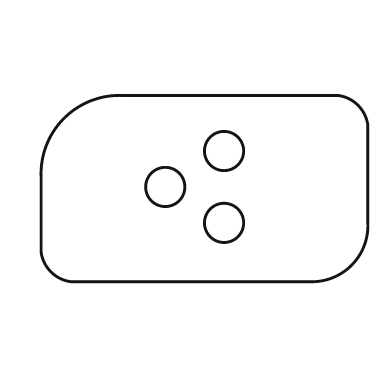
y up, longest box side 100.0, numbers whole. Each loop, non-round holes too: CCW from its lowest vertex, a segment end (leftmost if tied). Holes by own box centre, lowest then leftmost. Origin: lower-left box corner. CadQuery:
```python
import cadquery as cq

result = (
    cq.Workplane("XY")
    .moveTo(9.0, 0.0)
    .lineTo(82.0, 0.0)
    .threePointArc((95.0, 5.0), (100.0, 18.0))
    .lineTo(100.0, 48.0)
    .threePointArc((97.0, 54.0), (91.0, 57.0))
    .lineTo(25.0, 57.0)
    .threePointArc((7.0, 50.0), (0.0, 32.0))
    .lineTo(0.0, 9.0)
    .threePointArc((3.0, 3.0), (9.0, 0.0))
    .close()
    .moveTo(56.0, 18.0)
    .circle(6.0)
    .moveTo(38.0, 29.0)
    .circle(6.0)
    .moveTo(56.0, 40.0)
    .circle(6.0)
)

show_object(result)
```